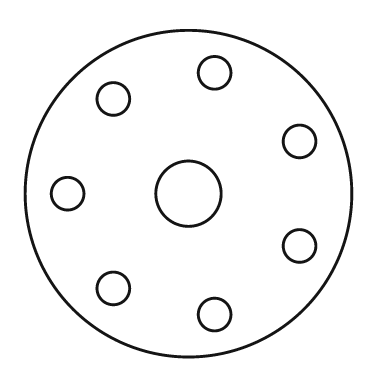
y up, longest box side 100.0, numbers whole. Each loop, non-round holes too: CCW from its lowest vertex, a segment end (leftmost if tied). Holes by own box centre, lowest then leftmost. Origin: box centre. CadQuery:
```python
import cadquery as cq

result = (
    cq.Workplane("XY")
    .moveTo(0.0, 0.0)
    .circle(50.0)
    .moveTo(8.0, -37.0)
    .circle(5.0)
    .moveTo(-23.0, -29.0)
    .circle(5.0)
    .moveTo(34.0, -16.0)
    .circle(5.0)
    .moveTo(-37.0, 0.0)
    .circle(5.0)
    .moveTo(0.0, 0.0)
    .circle(10.0)
    .moveTo(34.0, 16.0)
    .circle(5.0)
    .moveTo(-23.0, 29.0)
    .circle(5.0)
    .moveTo(8.0, 37.0)
    .circle(5.0)
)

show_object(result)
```